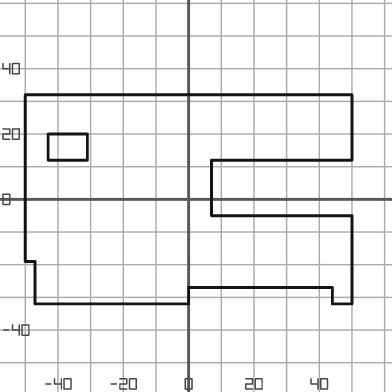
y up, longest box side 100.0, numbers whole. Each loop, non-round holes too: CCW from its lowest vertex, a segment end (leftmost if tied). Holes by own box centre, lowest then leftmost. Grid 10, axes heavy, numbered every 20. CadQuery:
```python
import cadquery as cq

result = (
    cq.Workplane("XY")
    .moveTo(-47.0, -32.0)
    .lineTo(0.0, -32.0)
    .lineTo(0.0, -27.0)
    .lineTo(44.0, -27.0)
    .lineTo(44.0, -32.0)
    .lineTo(50.0, -32.0)
    .lineTo(50.0, -5.0)
    .lineTo(7.0, -5.0)
    .lineTo(7.0, 12.0)
    .lineTo(50.0, 12.0)
    .lineTo(50.0, 32.0)
    .lineTo(-50.0, 32.0)
    .lineTo(-50.0, -19.0)
    .lineTo(-47.0, -19.0)
    .close()
    .moveTo(-43.0, 12.0)
    .lineTo(-31.0, 12.0)
    .lineTo(-31.0, 20.0)
    .lineTo(-43.0, 20.0)
    .close()
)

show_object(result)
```